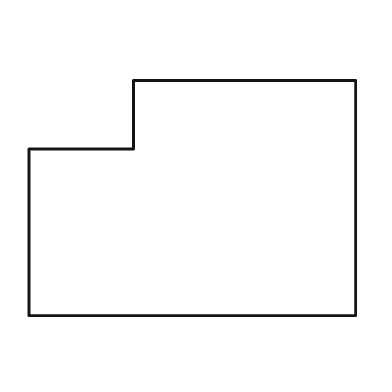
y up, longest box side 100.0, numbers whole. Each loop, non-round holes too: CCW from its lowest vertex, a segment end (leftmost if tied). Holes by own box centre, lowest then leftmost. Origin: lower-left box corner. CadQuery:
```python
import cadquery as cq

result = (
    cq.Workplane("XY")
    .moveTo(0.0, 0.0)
    .lineTo(100.0, 0.0)
    .lineTo(100.0, 72.0)
    .lineTo(32.0, 72.0)
    .lineTo(32.0, 51.0)
    .lineTo(0.0, 51.0)
    .close()
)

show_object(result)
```